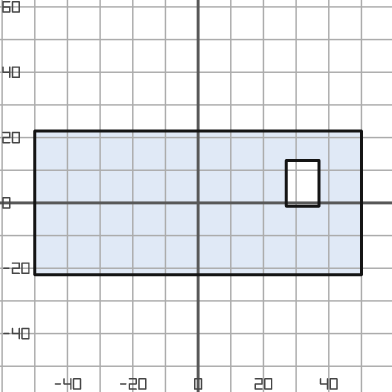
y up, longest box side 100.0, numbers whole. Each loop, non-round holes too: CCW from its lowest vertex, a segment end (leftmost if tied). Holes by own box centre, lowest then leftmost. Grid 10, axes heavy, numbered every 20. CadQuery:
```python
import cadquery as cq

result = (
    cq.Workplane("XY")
    .moveTo(-50.0, -22.0)
    .lineTo(50.0, -22.0)
    .lineTo(50.0, 22.0)
    .lineTo(-50.0, 22.0)
    .close()
    .moveTo(27.0, -1.0)
    .lineTo(37.0, -1.0)
    .lineTo(37.0, 13.0)
    .lineTo(27.0, 13.0)
    .close()
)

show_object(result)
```